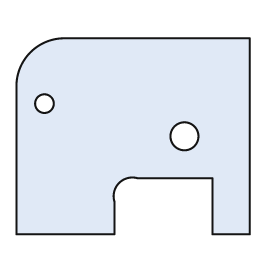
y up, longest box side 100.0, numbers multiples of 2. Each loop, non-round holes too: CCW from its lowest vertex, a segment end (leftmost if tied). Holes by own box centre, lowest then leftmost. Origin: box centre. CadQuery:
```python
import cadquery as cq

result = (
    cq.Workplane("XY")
    .moveTo(-50.0, -42.0)
    .lineTo(-8.0, -42.0)
    .lineTo(-8.0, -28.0)
    .threePointArc((-6.0, -20.0), (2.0, -18.0))
    .lineTo(34.0, -18.0)
    .lineTo(34.0, -42.0)
    .lineTo(50.0, -42.0)
    .lineTo(50.0, 42.0)
    .lineTo(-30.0, 42.0)
    .threePointArc((-44.0, 36.0), (-50.0, 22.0))
    .close()
    .moveTo(22.0, 0.0)
    .circle(6.0)
    .moveTo(-38.0, 14.0)
    .circle(4.0)
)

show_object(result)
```